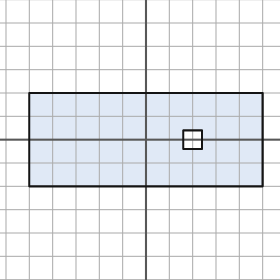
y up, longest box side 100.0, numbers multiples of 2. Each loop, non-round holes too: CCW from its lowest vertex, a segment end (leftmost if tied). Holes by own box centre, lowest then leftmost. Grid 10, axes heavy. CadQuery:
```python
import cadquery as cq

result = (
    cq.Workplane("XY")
    .moveTo(-50.0, -20.0)
    .lineTo(50.0, -20.0)
    .lineTo(50.0, 20.0)
    .lineTo(-50.0, 20.0)
    .close()
    .moveTo(16.0, -4.0)
    .lineTo(24.0, -4.0)
    .lineTo(24.0, 4.0)
    .lineTo(16.0, 4.0)
    .close()
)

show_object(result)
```